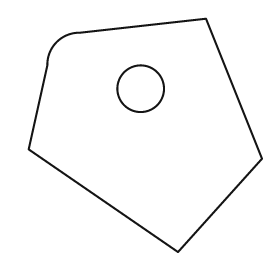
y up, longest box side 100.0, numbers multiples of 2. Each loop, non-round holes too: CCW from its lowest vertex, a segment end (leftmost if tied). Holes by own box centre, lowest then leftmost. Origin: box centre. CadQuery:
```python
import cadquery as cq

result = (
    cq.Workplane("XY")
    .moveTo(14.0, -50.0)
    .lineTo(50.0, -10.0)
    .lineTo(26.0, 50.0)
    .lineTo(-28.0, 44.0)
    .threePointArc((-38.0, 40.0), (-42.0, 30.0))
    .lineTo(-50.0, -6.0)
    .close()
    .moveTo(-2.0, 20.0)
    .circle(10.0)
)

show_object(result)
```